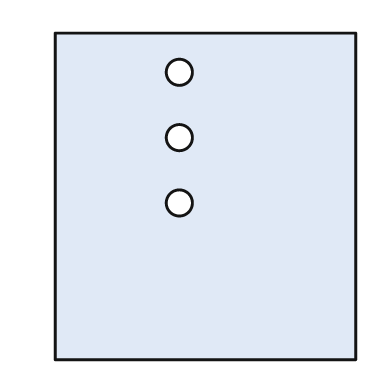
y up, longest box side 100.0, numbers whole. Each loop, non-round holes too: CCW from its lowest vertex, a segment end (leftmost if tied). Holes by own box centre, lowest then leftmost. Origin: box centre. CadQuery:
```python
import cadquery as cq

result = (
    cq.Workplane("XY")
    .moveTo(-46.0, -50.0)
    .lineTo(46.0, -50.0)
    .lineTo(46.0, 50.0)
    .lineTo(-46.0, 50.0)
    .close()
    .moveTo(-8.0, -2.0)
    .circle(4.0)
    .moveTo(-8.0, 18.0)
    .circle(4.0)
    .moveTo(-8.0, 38.0)
    .circle(4.0)
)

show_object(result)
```